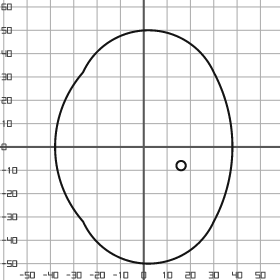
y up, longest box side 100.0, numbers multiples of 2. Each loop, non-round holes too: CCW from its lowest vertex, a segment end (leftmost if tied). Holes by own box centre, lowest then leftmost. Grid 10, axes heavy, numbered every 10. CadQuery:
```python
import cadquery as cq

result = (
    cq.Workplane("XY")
    .moveTo(-26.0, -32.0)
    .threePointArc((2.0, -50.0), (30.0, -32.0))
    .threePointArc((38.0, 0.0), (30.0, 32.0))
    .threePointArc((2.0, 50.0), (-26.0, 32.0))
    .threePointArc((-38.0, 0.0), (-26.0, -32.0))
    .close()
    .moveTo(16.0, -8.0)
    .circle(2.0)
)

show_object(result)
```